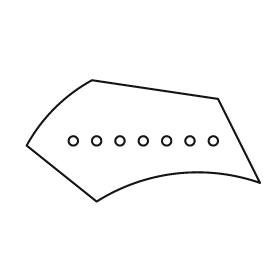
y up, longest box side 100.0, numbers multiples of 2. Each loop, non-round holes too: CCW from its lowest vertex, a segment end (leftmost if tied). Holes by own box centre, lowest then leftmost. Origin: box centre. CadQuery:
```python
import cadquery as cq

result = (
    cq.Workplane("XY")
    .moveTo(-20.0, -26.0)
    .threePointArc((14.0, -14.0), (50.0, -18.0))
    .lineTo(32.0, 18.0)
    .lineTo(-22.0, 26.0)
    .threePointArc((-38.0, 14.0), (-50.0, -2.0))
    .close()
    .moveTo(-30.0, 0.0)
    .circle(2.0)
    .moveTo(-20.0, 0.0)
    .circle(2.0)
    .moveTo(-10.0, 0.0)
    .circle(2.0)
    .moveTo(0.0, 0.0)
    .circle(2.0)
    .moveTo(10.0, 0.0)
    .circle(2.0)
    .moveTo(20.0, 0.0)
    .circle(2.0)
    .moveTo(30.0, 0.0)
    .circle(2.0)
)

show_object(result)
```